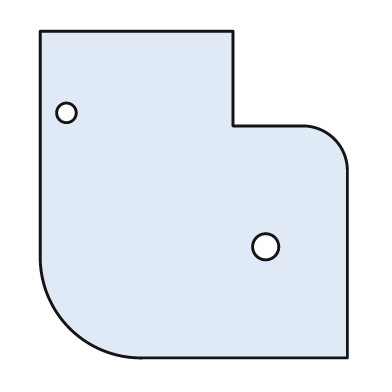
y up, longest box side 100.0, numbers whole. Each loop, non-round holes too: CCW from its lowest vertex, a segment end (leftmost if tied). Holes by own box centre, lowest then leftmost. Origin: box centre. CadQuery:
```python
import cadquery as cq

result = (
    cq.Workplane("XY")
    .moveTo(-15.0, -50.0)
    .lineTo(47.0, -50.0)
    .lineTo(47.0, 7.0)
    .threePointArc((43.0, 17.0), (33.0, 21.0))
    .lineTo(12.0, 21.0)
    .lineTo(12.0, 50.0)
    .lineTo(-47.0, 50.0)
    .lineTo(-47.0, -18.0)
    .threePointArc((-38.0, -41.0), (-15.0, -50.0))
    .close()
    .moveTo(22.0, -16.0)
    .circle(4.0)
    .moveTo(-39.0, 25.0)
    .circle(3.0)
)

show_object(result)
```